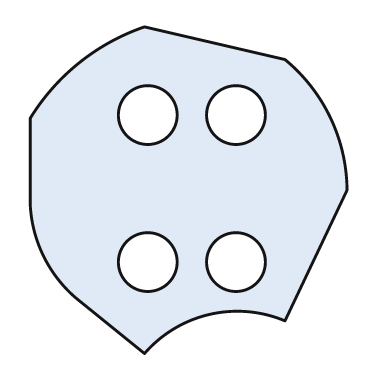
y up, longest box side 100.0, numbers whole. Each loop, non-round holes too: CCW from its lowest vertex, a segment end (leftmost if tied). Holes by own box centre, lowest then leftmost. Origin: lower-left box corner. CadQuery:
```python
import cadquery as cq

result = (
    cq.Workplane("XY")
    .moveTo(35.0, 0.0)
    .threePointArc((55.0, 12.0), (78.0, 10.0))
    .lineTo(97.0, 50.0)
    .threePointArc((92.0, 72.0), (78.0, 90.0))
    .lineTo(35.0, 100.0)
    .threePointArc((15.0, 89.0), (0.0, 72.0))
    .lineTo(0.0, 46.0)
    .threePointArc((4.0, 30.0), (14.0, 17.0))
    .close()
    .moveTo(36.0, 28.0)
    .circle(9.0)
    .moveTo(63.0, 28.0)
    .circle(9.0)
    .moveTo(36.0, 73.0)
    .circle(9.0)
    .moveTo(63.0, 73.0)
    .circle(9.0)
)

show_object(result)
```